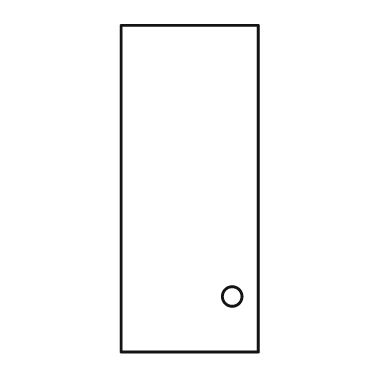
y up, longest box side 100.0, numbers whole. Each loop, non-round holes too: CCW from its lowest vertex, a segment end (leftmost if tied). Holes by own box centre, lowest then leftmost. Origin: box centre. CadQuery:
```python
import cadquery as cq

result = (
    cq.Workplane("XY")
    .moveTo(-21.0, -50.0)
    .lineTo(21.0, -50.0)
    .lineTo(21.0, 50.0)
    .lineTo(-21.0, 50.0)
    .close()
    .moveTo(13.0, -33.0)
    .circle(3.0)
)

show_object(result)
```